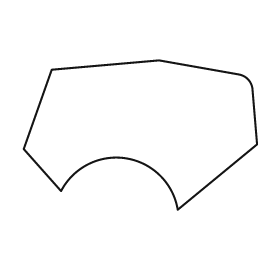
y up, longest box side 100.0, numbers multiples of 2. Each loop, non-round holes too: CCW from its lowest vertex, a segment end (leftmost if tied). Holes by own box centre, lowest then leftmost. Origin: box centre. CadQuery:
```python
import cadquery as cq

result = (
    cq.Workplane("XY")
    .moveTo(16.0, -32.0)
    .lineTo(50.0, -4.0)
    .lineTo(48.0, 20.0)
    .threePointArc((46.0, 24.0), (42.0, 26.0))
    .lineTo(8.0, 32.0)
    .lineTo(-38.0, 28.0)
    .lineTo(-50.0, -6.0)
    .lineTo(-34.0, -24.0)
    .threePointArc((-6.0, -10.0), (16.0, -32.0))
    .close()
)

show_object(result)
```